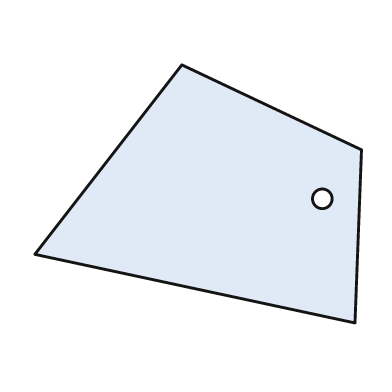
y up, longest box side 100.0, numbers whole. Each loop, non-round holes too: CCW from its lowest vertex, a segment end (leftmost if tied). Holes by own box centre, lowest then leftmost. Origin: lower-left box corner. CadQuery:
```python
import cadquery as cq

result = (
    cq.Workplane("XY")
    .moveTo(98.0, 0.0)
    .lineTo(100.0, 53.0)
    .lineTo(45.0, 79.0)
    .lineTo(0.0, 21.0)
    .close()
    .moveTo(88.0, 38.0)
    .circle(3.0)
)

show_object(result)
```